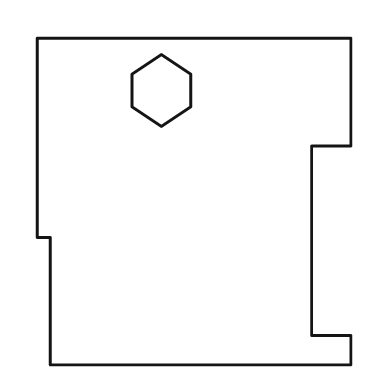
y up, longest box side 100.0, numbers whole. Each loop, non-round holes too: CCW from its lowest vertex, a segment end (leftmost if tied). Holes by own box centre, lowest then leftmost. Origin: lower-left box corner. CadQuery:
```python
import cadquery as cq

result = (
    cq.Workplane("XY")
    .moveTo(4.0, 0.0)
    .lineTo(96.0, 0.0)
    .lineTo(96.0, 9.0)
    .lineTo(84.0, 9.0)
    .lineTo(84.0, 67.0)
    .lineTo(96.0, 67.0)
    .lineTo(96.0, 100.0)
    .lineTo(0.0, 100.0)
    .lineTo(0.0, 39.0)
    .lineTo(4.0, 39.0)
    .close()
    .moveTo(38.0, 73.0)
    .lineTo(47.0, 79.0)
    .lineTo(47.0, 89.0)
    .lineTo(38.0, 95.0)
    .lineTo(29.0, 89.0)
    .lineTo(29.0, 79.0)
    .close()
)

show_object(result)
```